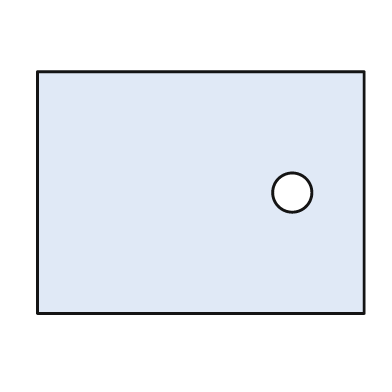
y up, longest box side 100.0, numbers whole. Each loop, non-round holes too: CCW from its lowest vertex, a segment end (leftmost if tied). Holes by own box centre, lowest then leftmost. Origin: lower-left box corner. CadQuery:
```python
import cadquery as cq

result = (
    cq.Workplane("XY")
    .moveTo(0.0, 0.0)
    .lineTo(100.0, 0.0)
    .lineTo(100.0, 74.0)
    .lineTo(0.0, 74.0)
    .close()
    .moveTo(78.0, 37.0)
    .circle(6.0)
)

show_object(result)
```